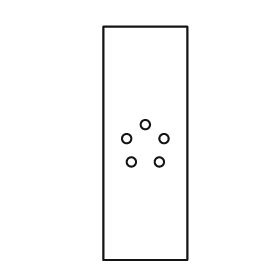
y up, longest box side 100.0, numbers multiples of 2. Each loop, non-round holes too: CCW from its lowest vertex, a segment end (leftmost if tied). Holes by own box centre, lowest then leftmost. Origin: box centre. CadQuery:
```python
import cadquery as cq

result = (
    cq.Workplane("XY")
    .moveTo(-18.0, -50.0)
    .lineTo(18.0, -50.0)
    .lineTo(18.0, 50.0)
    .lineTo(-18.0, 50.0)
    .close()
    .moveTo(-6.0, -8.0)
    .circle(2.0)
    .moveTo(6.0, -8.0)
    .circle(2.0)
    .moveTo(-8.0, 2.0)
    .circle(2.0)
    .moveTo(8.0, 2.0)
    .circle(2.0)
    .moveTo(0.0, 8.0)
    .circle(2.0)
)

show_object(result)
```